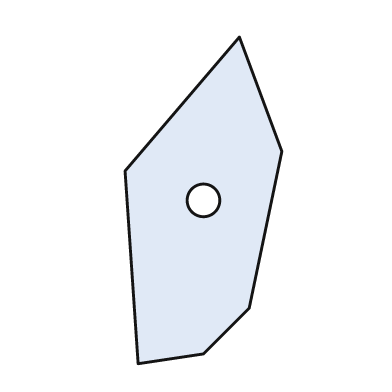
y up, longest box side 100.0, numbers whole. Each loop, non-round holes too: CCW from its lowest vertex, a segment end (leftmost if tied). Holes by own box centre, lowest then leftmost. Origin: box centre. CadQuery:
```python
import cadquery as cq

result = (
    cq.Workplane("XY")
    .moveTo(-20.0, -50.0)
    .lineTo(0.0, -47.0)
    .lineTo(14.0, -33.0)
    .lineTo(24.0, 15.0)
    .lineTo(11.0, 50.0)
    .lineTo(-24.0, 9.0)
    .close()
    .moveTo(0.0, 0.0)
    .circle(5.0)
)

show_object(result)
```